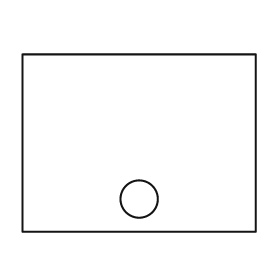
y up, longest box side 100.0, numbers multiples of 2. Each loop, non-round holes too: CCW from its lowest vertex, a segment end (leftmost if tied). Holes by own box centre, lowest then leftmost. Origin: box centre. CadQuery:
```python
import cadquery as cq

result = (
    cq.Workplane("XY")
    .moveTo(-50.0, -38.0)
    .lineTo(50.0, -38.0)
    .lineTo(50.0, 38.0)
    .lineTo(-50.0, 38.0)
    .close()
    .moveTo(0.0, -24.0)
    .circle(8.0)
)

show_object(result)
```